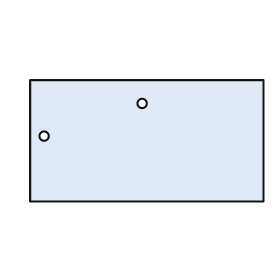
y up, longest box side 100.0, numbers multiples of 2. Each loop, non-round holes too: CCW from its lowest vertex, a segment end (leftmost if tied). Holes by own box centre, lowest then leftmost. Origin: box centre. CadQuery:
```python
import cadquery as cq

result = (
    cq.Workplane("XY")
    .moveTo(-50.0, -26.0)
    .lineTo(50.0, -26.0)
    .lineTo(50.0, 26.0)
    .lineTo(-50.0, 26.0)
    .close()
    .moveTo(-44.0, 2.0)
    .circle(2.0)
    .moveTo(-2.0, 16.0)
    .circle(2.0)
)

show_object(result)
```